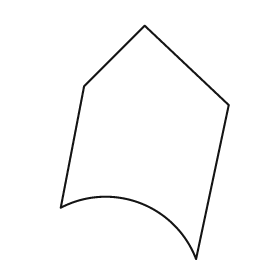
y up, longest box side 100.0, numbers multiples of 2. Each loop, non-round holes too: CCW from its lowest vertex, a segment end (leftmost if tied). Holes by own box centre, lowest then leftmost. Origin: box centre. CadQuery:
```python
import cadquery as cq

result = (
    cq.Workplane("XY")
    .moveTo(22.0, -50.0)
    .lineTo(36.0, 16.0)
    .lineTo(0.0, 50.0)
    .lineTo(-26.0, 24.0)
    .lineTo(-36.0, -28.0)
    .threePointArc((-2.0, -26.0), (22.0, -50.0))
    .close()
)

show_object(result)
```